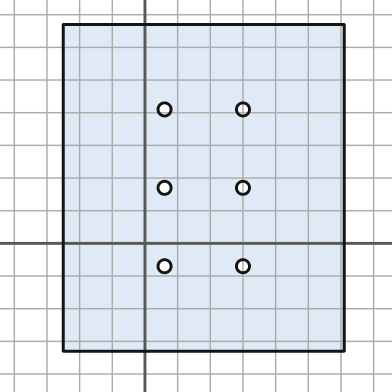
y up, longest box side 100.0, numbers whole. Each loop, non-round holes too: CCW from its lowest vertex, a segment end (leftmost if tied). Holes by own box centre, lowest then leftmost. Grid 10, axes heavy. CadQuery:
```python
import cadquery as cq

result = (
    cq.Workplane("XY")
    .moveTo(-25.0, -33.0)
    .lineTo(61.0, -33.0)
    .lineTo(61.0, 67.0)
    .lineTo(-25.0, 67.0)
    .close()
    .moveTo(6.0, -7.0)
    .circle(2.0)
    .moveTo(30.0, -7.0)
    .circle(2.0)
    .moveTo(6.0, 17.0)
    .circle(2.0)
    .moveTo(30.0, 17.0)
    .circle(2.0)
    .moveTo(6.0, 41.0)
    .circle(2.0)
    .moveTo(30.0, 41.0)
    .circle(2.0)
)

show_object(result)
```